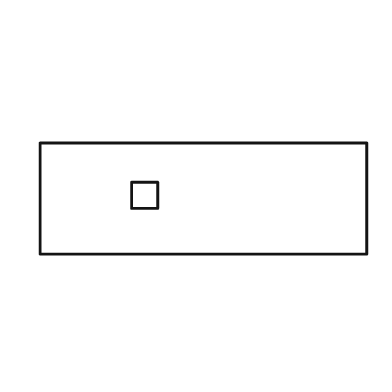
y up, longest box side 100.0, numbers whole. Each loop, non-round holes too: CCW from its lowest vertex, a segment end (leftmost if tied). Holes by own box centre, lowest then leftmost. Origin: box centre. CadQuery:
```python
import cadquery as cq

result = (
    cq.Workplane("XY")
    .moveTo(-50.0, -17.0)
    .lineTo(50.0, -17.0)
    .lineTo(50.0, 17.0)
    .lineTo(-50.0, 17.0)
    .close()
    .moveTo(-22.0, -3.0)
    .lineTo(-14.0, -3.0)
    .lineTo(-14.0, 5.0)
    .lineTo(-22.0, 5.0)
    .close()
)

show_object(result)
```